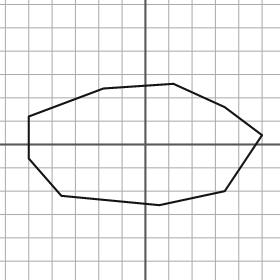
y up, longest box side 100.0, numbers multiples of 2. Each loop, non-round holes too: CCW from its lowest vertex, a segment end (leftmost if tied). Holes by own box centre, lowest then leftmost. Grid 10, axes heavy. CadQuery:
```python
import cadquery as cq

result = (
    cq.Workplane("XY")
    .moveTo(6.0, -26.0)
    .lineTo(34.0, -20.0)
    .lineTo(50.0, 4.0)
    .lineTo(34.0, 16.0)
    .lineTo(12.0, 26.0)
    .lineTo(-18.0, 24.0)
    .lineTo(-50.0, 12.0)
    .lineTo(-50.0, -6.0)
    .lineTo(-36.0, -22.0)
    .close()
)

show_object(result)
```